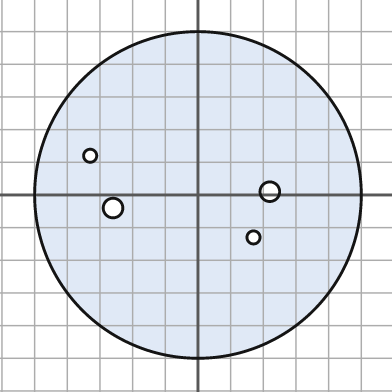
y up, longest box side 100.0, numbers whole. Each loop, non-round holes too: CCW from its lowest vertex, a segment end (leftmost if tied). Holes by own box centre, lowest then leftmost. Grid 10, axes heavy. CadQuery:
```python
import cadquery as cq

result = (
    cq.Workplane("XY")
    .moveTo(0.0, 0.0)
    .circle(50.0)
    .moveTo(17.0, -13.0)
    .circle(2.0)
    .moveTo(-26.0, -4.0)
    .circle(3.0)
    .moveTo(22.0, 1.0)
    .circle(3.0)
    .moveTo(-33.0, 12.0)
    .circle(2.0)
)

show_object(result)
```